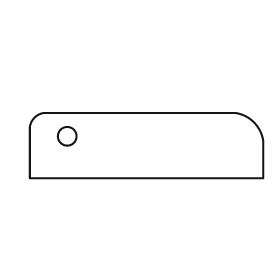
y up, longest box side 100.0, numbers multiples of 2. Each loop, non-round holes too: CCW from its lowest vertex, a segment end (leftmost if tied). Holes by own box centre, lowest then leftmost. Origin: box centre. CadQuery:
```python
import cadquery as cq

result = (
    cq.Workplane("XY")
    .moveTo(-50.0, -14.0)
    .lineTo(50.0, -14.0)
    .lineTo(50.0, 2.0)
    .threePointArc((46.0, 10.0), (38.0, 14.0))
    .lineTo(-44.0, 14.0)
    .threePointArc((-48.0, 12.0), (-50.0, 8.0))
    .close()
    .moveTo(-34.0, 4.0)
    .circle(4.0)
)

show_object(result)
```